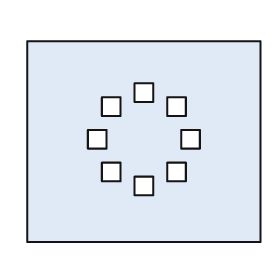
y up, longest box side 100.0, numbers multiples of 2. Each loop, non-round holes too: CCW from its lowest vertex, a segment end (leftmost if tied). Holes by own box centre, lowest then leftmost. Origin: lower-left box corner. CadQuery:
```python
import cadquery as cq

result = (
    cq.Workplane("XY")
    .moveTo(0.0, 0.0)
    .lineTo(100.0, 0.0)
    .lineTo(100.0, 86.0)
    .lineTo(0.0, 86.0)
    .close()
    .moveTo(46.0, 20.0)
    .lineTo(54.0, 20.0)
    .lineTo(54.0, 28.0)
    .lineTo(46.0, 28.0)
    .close()
    .moveTo(32.0, 26.0)
    .lineTo(40.0, 26.0)
    .lineTo(40.0, 34.0)
    .lineTo(32.0, 34.0)
    .close()
    .moveTo(60.0, 26.0)
    .lineTo(68.0, 26.0)
    .lineTo(68.0, 34.0)
    .lineTo(60.0, 34.0)
    .close()
    .moveTo(26.0, 40.0)
    .lineTo(34.0, 40.0)
    .lineTo(34.0, 48.0)
    .lineTo(26.0, 48.0)
    .close()
    .moveTo(66.0, 40.0)
    .lineTo(74.0, 40.0)
    .lineTo(74.0, 48.0)
    .lineTo(66.0, 48.0)
    .close()
    .moveTo(32.0, 54.0)
    .lineTo(40.0, 54.0)
    .lineTo(40.0, 62.0)
    .lineTo(32.0, 62.0)
    .close()
    .moveTo(60.0, 54.0)
    .lineTo(68.0, 54.0)
    .lineTo(68.0, 62.0)
    .lineTo(60.0, 62.0)
    .close()
    .moveTo(46.0, 60.0)
    .lineTo(54.0, 60.0)
    .lineTo(54.0, 68.0)
    .lineTo(46.0, 68.0)
    .close()
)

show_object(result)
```